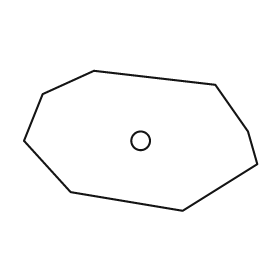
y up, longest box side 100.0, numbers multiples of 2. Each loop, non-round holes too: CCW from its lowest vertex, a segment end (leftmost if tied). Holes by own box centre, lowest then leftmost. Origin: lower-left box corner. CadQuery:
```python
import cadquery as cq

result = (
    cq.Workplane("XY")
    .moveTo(68.0, 0.0)
    .lineTo(100.0, 20.0)
    .lineTo(96.0, 34.0)
    .lineTo(82.0, 54.0)
    .lineTo(30.0, 60.0)
    .lineTo(8.0, 50.0)
    .lineTo(0.0, 30.0)
    .lineTo(20.0, 8.0)
    .close()
    .moveTo(50.0, 30.0)
    .circle(4.0)
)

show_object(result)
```